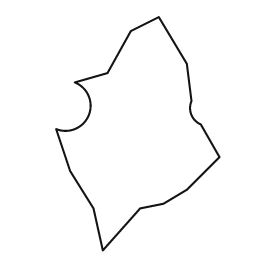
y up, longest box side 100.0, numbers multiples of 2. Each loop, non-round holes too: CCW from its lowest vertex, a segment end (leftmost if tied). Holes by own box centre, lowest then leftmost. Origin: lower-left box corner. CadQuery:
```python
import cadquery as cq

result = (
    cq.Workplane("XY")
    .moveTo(20.0, 0.0)
    .lineTo(36.0, 18.0)
    .lineTo(46.0, 20.0)
    .lineTo(56.0, 26.0)
    .lineTo(70.0, 40.0)
    .lineTo(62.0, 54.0)
    .threePointArc((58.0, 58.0), (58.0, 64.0))
    .lineTo(56.0, 80.0)
    .lineTo(44.0, 100.0)
    .lineTo(32.0, 94.0)
    .lineTo(22.0, 76.0)
    .lineTo(8.0, 72.0)
    .threePointArc((14.0, 58.0), (0.0, 52.0))
    .lineTo(6.0, 34.0)
    .lineTo(16.0, 18.0)
    .close()
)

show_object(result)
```